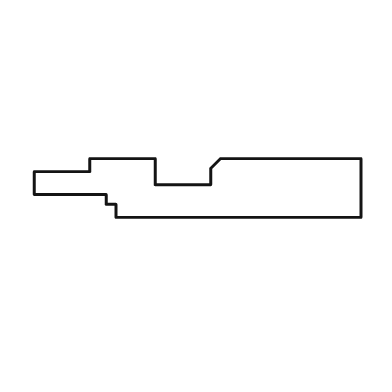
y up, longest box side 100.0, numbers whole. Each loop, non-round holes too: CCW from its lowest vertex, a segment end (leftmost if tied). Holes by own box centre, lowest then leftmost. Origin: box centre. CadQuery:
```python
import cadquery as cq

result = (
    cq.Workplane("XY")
    .moveTo(-25.0, -9.0)
    .lineTo(50.0, -9.0)
    .lineTo(50.0, 9.0)
    .lineTo(7.0, 9.0)
    .lineTo(4.0, 6.0)
    .lineTo(4.0, 1.0)
    .lineTo(-13.0, 1.0)
    .lineTo(-13.0, 9.0)
    .lineTo(-33.0, 9.0)
    .lineTo(-33.0, 5.0)
    .lineTo(-50.0, 5.0)
    .lineTo(-50.0, -2.0)
    .lineTo(-28.0, -2.0)
    .lineTo(-28.0, -5.0)
    .lineTo(-25.0, -5.0)
    .close()
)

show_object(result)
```